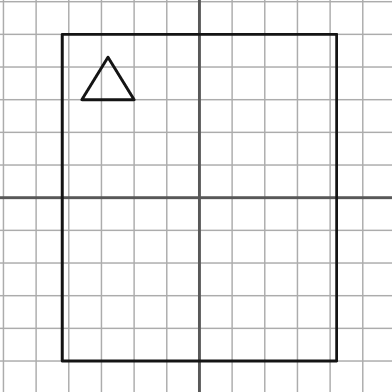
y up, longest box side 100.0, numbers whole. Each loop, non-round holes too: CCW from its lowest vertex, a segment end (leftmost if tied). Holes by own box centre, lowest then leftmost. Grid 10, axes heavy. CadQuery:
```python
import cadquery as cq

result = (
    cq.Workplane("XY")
    .moveTo(-42.0, -50.0)
    .lineTo(42.0, -50.0)
    .lineTo(42.0, 50.0)
    .lineTo(-42.0, 50.0)
    .close()
    .moveTo(-36.0, 30.0)
    .lineTo(-20.0, 30.0)
    .lineTo(-28.0, 43.0)
    .close()
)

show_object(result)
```